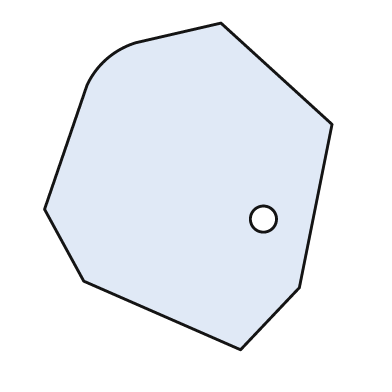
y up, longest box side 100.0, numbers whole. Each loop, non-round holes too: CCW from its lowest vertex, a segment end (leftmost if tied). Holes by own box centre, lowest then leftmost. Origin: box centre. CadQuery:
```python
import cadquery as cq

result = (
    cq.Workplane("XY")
    .moveTo(16.0, -50.0)
    .lineTo(34.0, -31.0)
    .lineTo(44.0, 19.0)
    .lineTo(10.0, 50.0)
    .lineTo(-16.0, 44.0)
    .threePointArc((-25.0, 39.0), (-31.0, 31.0))
    .lineTo(-44.0, -7.0)
    .lineTo(-32.0, -29.0)
    .close()
    .moveTo(23.0, -10.0)
    .circle(4.0)
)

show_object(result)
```